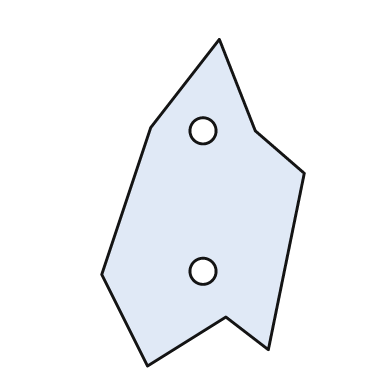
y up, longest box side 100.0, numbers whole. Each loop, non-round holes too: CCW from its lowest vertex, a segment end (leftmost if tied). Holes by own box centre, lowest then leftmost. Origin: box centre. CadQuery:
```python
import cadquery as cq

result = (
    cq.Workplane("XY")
    .moveTo(-17.0, -50.0)
    .lineTo(7.0, -35.0)
    .lineTo(20.0, -45.0)
    .lineTo(31.0, 9.0)
    .lineTo(16.0, 22.0)
    .lineTo(5.0, 50.0)
    .lineTo(-16.0, 23.0)
    .lineTo(-31.0, -22.0)
    .close()
    .moveTo(0.0, -21.0)
    .circle(4.0)
    .moveTo(0.0, 22.0)
    .circle(4.0)
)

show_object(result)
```